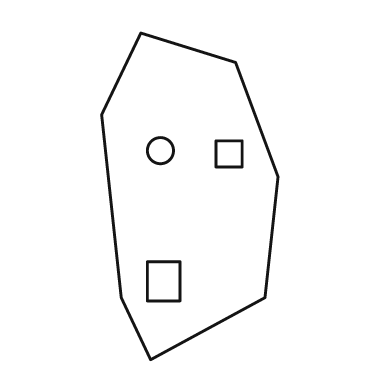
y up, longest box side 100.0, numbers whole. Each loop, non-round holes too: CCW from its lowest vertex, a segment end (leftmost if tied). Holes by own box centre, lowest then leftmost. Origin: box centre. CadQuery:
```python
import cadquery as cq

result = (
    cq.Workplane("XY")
    .moveTo(-12.0, -50.0)
    .lineTo(23.0, -31.0)
    .lineTo(27.0, 6.0)
    .lineTo(14.0, 41.0)
    .lineTo(-15.0, 50.0)
    .lineTo(-27.0, 25.0)
    .lineTo(-21.0, -31.0)
    .close()
    .moveTo(-13.0, -32.0)
    .lineTo(-3.0, -32.0)
    .lineTo(-3.0, -20.0)
    .lineTo(-13.0, -20.0)
    .close()
    .moveTo(8.0, 9.0)
    .lineTo(16.0, 9.0)
    .lineTo(16.0, 17.0)
    .lineTo(8.0, 17.0)
    .close()
    .moveTo(-9.0, 14.0)
    .circle(4.0)
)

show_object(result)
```